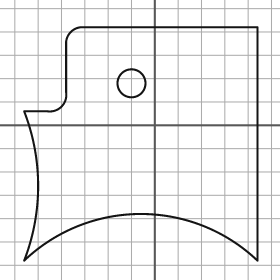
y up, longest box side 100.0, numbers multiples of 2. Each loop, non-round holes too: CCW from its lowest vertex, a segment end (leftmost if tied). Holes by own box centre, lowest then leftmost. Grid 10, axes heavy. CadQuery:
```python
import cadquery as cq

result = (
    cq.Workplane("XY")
    .moveTo(-56.0, -58.0)
    .threePointArc((-6.0, -38.0), (44.0, -58.0))
    .lineTo(44.0, 42.0)
    .lineTo(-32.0, 42.0)
    .threePointArc((-36.0, 40.0), (-38.0, 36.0))
    .lineTo(-38.0, 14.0)
    .threePointArc((-40.0, 8.0), (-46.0, 6.0))
    .lineTo(-56.0, 6.0)
    .threePointArc((-50.0, -26.0), (-56.0, -58.0))
    .close()
    .moveTo(-10.0, 18.0)
    .circle(6.0)
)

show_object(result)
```